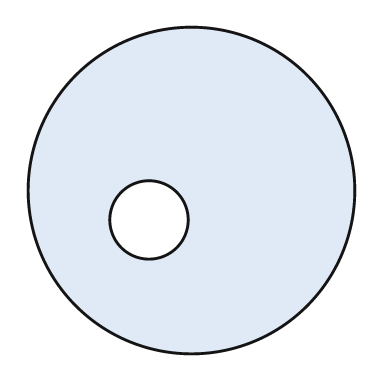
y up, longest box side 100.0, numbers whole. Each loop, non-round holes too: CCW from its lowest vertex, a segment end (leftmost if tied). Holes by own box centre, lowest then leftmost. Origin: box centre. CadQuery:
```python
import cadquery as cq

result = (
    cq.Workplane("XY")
    .moveTo(0.0, 0.0)
    .circle(50.0)
    .moveTo(-13.0, -9.0)
    .circle(12.0)
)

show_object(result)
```